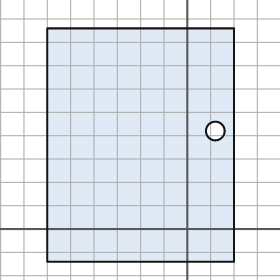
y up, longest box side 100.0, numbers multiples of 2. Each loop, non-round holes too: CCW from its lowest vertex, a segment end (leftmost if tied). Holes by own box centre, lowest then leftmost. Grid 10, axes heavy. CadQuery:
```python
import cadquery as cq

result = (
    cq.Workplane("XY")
    .moveTo(-60.0, -14.0)
    .lineTo(20.0, -14.0)
    .lineTo(20.0, 86.0)
    .lineTo(-60.0, 86.0)
    .close()
    .moveTo(12.0, 42.0)
    .circle(4.0)
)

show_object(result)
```